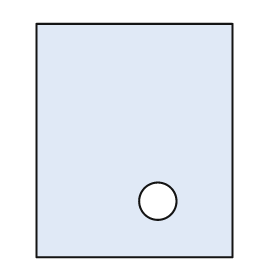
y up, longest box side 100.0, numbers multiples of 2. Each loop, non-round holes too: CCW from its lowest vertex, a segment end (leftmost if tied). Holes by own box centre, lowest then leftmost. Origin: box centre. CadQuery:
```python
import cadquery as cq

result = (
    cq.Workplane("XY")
    .moveTo(-42.0, -50.0)
    .lineTo(42.0, -50.0)
    .lineTo(42.0, 50.0)
    .lineTo(-42.0, 50.0)
    .close()
    .moveTo(10.0, -26.0)
    .circle(8.0)
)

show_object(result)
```